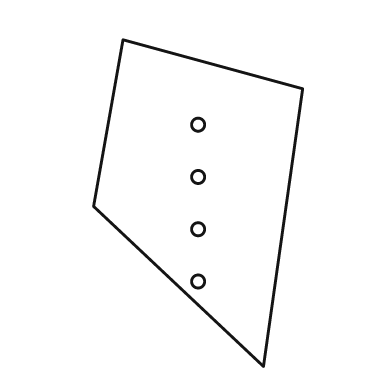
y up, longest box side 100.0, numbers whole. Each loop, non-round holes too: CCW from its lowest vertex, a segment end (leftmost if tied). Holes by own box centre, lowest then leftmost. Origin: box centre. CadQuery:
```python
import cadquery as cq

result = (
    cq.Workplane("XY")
    .moveTo(20.0, -50.0)
    .lineTo(32.0, 35.0)
    .lineTo(-23.0, 50.0)
    .lineTo(-32.0, -1.0)
    .close()
    .moveTo(0.0, -24.0)
    .circle(2.0)
    .moveTo(0.0, -8.0)
    .circle(2.0)
    .moveTo(0.0, 8.0)
    .circle(2.0)
    .moveTo(0.0, 24.0)
    .circle(2.0)
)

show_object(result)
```